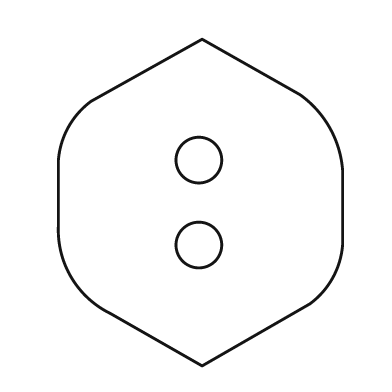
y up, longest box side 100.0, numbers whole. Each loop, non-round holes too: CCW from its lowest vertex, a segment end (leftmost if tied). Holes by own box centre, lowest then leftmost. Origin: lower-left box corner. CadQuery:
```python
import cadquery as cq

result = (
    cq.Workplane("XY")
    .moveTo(44.0, 0.0)
    .lineTo(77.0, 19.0)
    .threePointArc((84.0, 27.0), (87.0, 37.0))
    .lineTo(87.0, 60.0)
    .threePointArc((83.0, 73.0), (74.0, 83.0))
    .lineTo(44.0, 100.0)
    .lineTo(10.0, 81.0)
    .threePointArc((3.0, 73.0), (0.0, 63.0))
    .lineTo(0.0, 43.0)
    .threePointArc((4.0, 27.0), (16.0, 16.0))
    .close()
    .moveTo(43.0, 37.0)
    .circle(7.0)
    .moveTo(43.0, 63.0)
    .circle(7.0)
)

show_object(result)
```